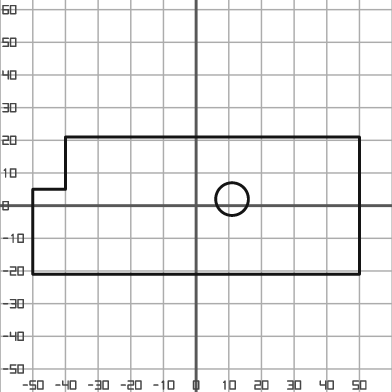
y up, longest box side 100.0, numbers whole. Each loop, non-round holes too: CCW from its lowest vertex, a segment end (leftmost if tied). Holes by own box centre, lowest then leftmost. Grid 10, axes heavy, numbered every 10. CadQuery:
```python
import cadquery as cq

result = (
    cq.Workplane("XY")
    .moveTo(-50.0, -21.0)
    .lineTo(50.0, -21.0)
    .lineTo(50.0, 21.0)
    .lineTo(-40.0, 21.0)
    .lineTo(-40.0, 5.0)
    .lineTo(-50.0, 5.0)
    .close()
    .moveTo(11.0, 2.0)
    .circle(5.0)
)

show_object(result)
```